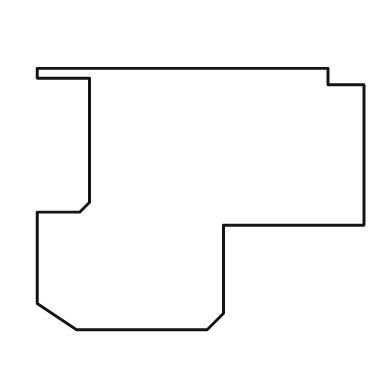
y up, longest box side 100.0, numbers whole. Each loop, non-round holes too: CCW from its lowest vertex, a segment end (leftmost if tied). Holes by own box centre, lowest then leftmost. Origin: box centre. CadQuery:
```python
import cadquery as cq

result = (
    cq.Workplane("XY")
    .moveTo(-38.0, -40.0)
    .lineTo(2.0, -40.0)
    .lineTo(7.0, -35.0)
    .lineTo(7.0, -8.0)
    .lineTo(50.0, -8.0)
    .lineTo(50.0, 35.0)
    .lineTo(39.0, 35.0)
    .lineTo(39.0, 40.0)
    .lineTo(-50.0, 40.0)
    .lineTo(-50.0, 37.0)
    .lineTo(-34.0, 37.0)
    .lineTo(-34.0, -1.0)
    .lineTo(-37.0, -4.0)
    .lineTo(-50.0, -4.0)
    .lineTo(-50.0, -32.0)
    .close()
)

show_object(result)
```